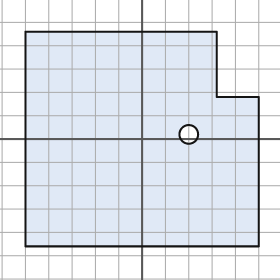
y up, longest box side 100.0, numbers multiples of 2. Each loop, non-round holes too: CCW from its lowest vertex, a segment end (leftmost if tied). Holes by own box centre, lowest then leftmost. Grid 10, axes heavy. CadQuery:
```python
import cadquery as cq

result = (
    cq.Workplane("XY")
    .moveTo(-50.0, -46.0)
    .lineTo(50.0, -46.0)
    .lineTo(50.0, 18.0)
    .lineTo(32.0, 18.0)
    .lineTo(32.0, 46.0)
    .lineTo(-50.0, 46.0)
    .close()
    .moveTo(20.0, 2.0)
    .circle(4.0)
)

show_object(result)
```